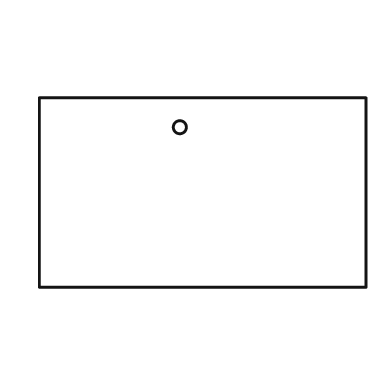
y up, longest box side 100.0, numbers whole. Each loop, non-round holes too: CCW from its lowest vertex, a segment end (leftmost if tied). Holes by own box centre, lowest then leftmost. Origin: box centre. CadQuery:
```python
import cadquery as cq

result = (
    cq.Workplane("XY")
    .moveTo(-50.0, -29.0)
    .lineTo(50.0, -29.0)
    .lineTo(50.0, 29.0)
    .lineTo(-50.0, 29.0)
    .close()
    .moveTo(-7.0, 20.0)
    .circle(2.0)
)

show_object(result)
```